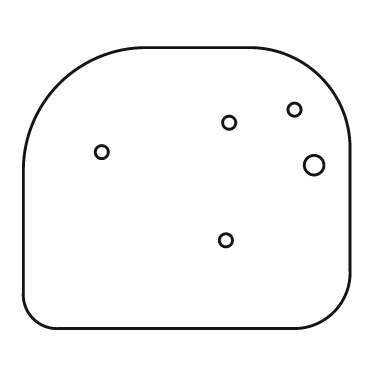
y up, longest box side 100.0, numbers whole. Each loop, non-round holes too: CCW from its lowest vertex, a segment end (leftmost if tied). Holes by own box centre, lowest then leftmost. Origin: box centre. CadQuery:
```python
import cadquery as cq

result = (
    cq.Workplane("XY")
    .moveTo(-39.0, -43.0)
    .lineTo(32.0, -43.0)
    .threePointArc((45.0, -38.0), (50.0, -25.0))
    .lineTo(50.0, 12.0)
    .threePointArc((41.0, 34.0), (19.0, 43.0))
    .lineTo(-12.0, 43.0)
    .threePointArc((-39.0, 32.0), (-50.0, 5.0))
    .lineTo(-50.0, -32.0)
    .threePointArc((-47.0, -40.0), (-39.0, -43.0))
    .close()
    .moveTo(12.0, -16.0)
    .circle(2.0)
    .moveTo(39.0, 7.0)
    .circle(3.0)
    .moveTo(-26.0, 11.0)
    .circle(2.0)
    .moveTo(13.0, 20.0)
    .circle(2.0)
    .moveTo(33.0, 24.0)
    .circle(2.0)
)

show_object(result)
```